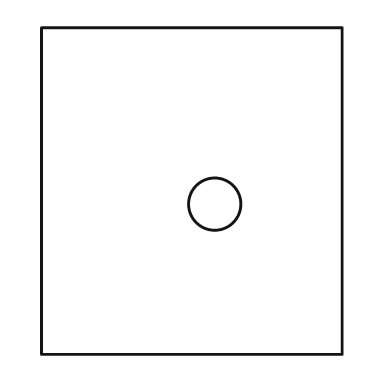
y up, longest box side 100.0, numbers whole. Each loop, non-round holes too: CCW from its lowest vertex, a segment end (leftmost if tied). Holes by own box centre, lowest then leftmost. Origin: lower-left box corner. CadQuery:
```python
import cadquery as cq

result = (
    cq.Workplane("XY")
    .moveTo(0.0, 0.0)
    .lineTo(92.0, 0.0)
    .lineTo(92.0, 100.0)
    .lineTo(0.0, 100.0)
    .close()
    .moveTo(53.0, 46.0)
    .circle(8.0)
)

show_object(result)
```